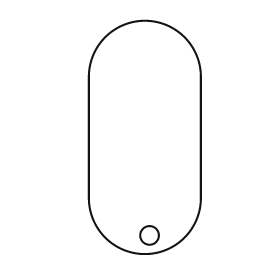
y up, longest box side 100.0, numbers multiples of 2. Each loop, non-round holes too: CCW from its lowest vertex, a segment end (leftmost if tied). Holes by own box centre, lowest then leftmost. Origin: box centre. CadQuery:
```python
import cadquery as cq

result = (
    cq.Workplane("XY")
    .moveTo(-24.0, -26.0)
    .threePointArc((0.0, -50.0), (24.0, -26.0))
    .lineTo(24.0, 26.0)
    .threePointArc((0.0, 50.0), (-24.0, 26.0))
    .close()
    .moveTo(2.0, -42.0)
    .circle(4.0)
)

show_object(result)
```